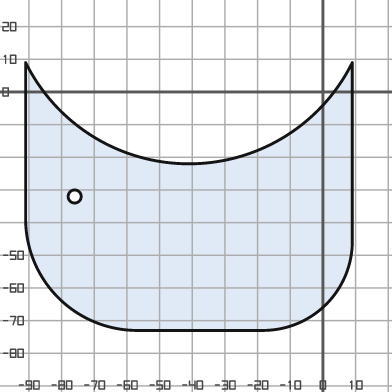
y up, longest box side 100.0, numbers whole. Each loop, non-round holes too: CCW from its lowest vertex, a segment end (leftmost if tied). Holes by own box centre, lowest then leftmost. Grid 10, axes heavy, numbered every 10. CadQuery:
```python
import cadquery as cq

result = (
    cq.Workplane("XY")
    .moveTo(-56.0, -73.0)
    .lineTo(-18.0, -73.0)
    .threePointArc((1.0, -65.0), (9.0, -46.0))
    .lineTo(9.0, 9.0)
    .threePointArc((-41.0, -22.0), (-91.0, 9.0))
    .lineTo(-91.0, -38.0)
    .threePointArc((-81.0, -63.0), (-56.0, -73.0))
    .close()
    .moveTo(-76.0, -32.0)
    .circle(2.0)
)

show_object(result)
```